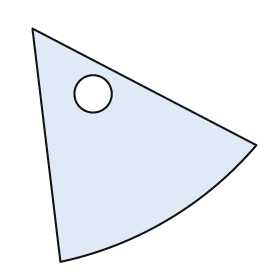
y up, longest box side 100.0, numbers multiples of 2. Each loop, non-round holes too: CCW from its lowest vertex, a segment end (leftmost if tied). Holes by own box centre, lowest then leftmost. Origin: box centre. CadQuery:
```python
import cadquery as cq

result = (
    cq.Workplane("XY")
    .moveTo(-36.0, -50.0)
    .threePointArc((10.0, -32.0), (48.0, 0.0))
    .lineTo(-48.0, 50.0)
    .close()
    .moveTo(-22.0, 22.0)
    .circle(8.0)
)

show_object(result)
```